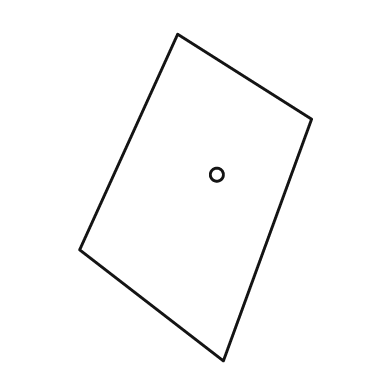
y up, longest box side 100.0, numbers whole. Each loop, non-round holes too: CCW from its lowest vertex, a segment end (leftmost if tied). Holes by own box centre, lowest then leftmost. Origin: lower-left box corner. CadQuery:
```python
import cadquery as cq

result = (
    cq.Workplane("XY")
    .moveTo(44.0, 0.0)
    .lineTo(71.0, 74.0)
    .lineTo(30.0, 100.0)
    .lineTo(0.0, 34.0)
    .close()
    .moveTo(42.0, 57.0)
    .circle(2.0)
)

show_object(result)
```